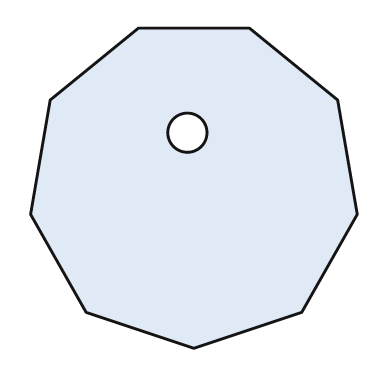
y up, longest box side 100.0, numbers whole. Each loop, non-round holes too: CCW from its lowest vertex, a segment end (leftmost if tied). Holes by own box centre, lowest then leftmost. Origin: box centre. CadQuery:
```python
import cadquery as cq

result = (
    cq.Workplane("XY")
    .moveTo(0.0, -49.0)
    .lineTo(33.0, -38.0)
    .lineTo(50.0, -8.0)
    .lineTo(44.0, 27.0)
    .lineTo(17.0, 49.0)
    .lineTo(-17.0, 49.0)
    .lineTo(-44.0, 27.0)
    .lineTo(-50.0, -8.0)
    .lineTo(-33.0, -38.0)
    .close()
    .moveTo(-2.0, 17.0)
    .circle(6.0)
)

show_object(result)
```